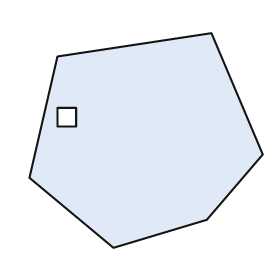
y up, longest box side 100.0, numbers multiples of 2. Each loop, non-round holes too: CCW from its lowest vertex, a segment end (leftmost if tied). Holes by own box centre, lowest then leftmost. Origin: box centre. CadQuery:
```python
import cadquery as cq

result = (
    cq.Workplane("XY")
    .moveTo(-14.0, -46.0)
    .lineTo(26.0, -34.0)
    .lineTo(50.0, -6.0)
    .lineTo(28.0, 46.0)
    .lineTo(-38.0, 36.0)
    .lineTo(-50.0, -16.0)
    .close()
    .moveTo(-38.0, 6.0)
    .lineTo(-30.0, 6.0)
    .lineTo(-30.0, 14.0)
    .lineTo(-38.0, 14.0)
    .close()
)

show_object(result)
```